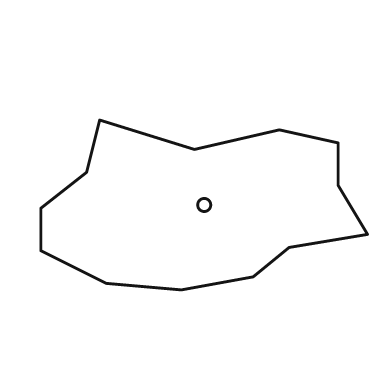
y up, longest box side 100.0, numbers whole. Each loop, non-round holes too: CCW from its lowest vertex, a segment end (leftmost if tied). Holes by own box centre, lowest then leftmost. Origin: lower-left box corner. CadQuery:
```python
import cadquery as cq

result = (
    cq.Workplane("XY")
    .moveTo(43.0, 0.0)
    .lineTo(65.0, 4.0)
    .lineTo(76.0, 13.0)
    .lineTo(100.0, 17.0)
    .lineTo(91.0, 32.0)
    .lineTo(91.0, 45.0)
    .lineTo(73.0, 49.0)
    .lineTo(47.0, 43.0)
    .lineTo(18.0, 52.0)
    .lineTo(14.0, 36.0)
    .lineTo(0.0, 25.0)
    .lineTo(0.0, 12.0)
    .lineTo(20.0, 2.0)
    .close()
    .moveTo(50.0, 26.0)
    .circle(2.0)
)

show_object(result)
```